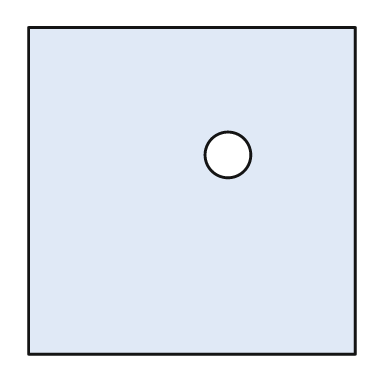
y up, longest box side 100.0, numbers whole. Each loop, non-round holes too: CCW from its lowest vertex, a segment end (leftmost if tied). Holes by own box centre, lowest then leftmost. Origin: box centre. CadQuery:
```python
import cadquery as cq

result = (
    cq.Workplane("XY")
    .moveTo(-50.0, -50.0)
    .lineTo(50.0, -50.0)
    .lineTo(50.0, 50.0)
    .lineTo(-50.0, 50.0)
    .close()
    .moveTo(11.0, 11.0)
    .circle(7.0)
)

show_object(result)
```